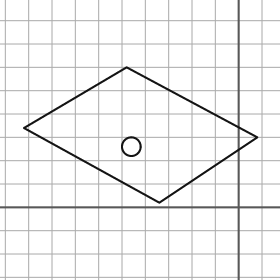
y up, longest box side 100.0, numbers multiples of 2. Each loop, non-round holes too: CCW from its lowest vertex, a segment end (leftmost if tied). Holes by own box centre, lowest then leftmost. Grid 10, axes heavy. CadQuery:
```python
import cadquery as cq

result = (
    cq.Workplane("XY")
    .moveTo(-34.0, 2.0)
    .lineTo(8.0, 30.0)
    .lineTo(-48.0, 60.0)
    .lineTo(-92.0, 34.0)
    .close()
    .moveTo(-46.0, 26.0)
    .circle(4.0)
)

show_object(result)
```